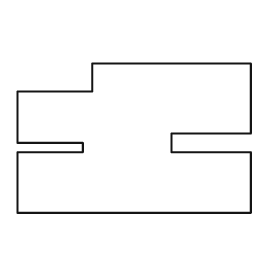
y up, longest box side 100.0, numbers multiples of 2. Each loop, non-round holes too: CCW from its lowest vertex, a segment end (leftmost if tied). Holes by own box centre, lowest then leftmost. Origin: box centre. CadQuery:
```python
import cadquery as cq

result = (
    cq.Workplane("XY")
    .moveTo(-50.0, -32.0)
    .lineTo(50.0, -32.0)
    .lineTo(50.0, -6.0)
    .lineTo(16.0, -6.0)
    .lineTo(16.0, 2.0)
    .lineTo(50.0, 2.0)
    .lineTo(50.0, 32.0)
    .lineTo(-18.0, 32.0)
    .lineTo(-18.0, 20.0)
    .lineTo(-50.0, 20.0)
    .lineTo(-50.0, -2.0)
    .lineTo(-22.0, -2.0)
    .lineTo(-22.0, -6.0)
    .lineTo(-50.0, -6.0)
    .close()
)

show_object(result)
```